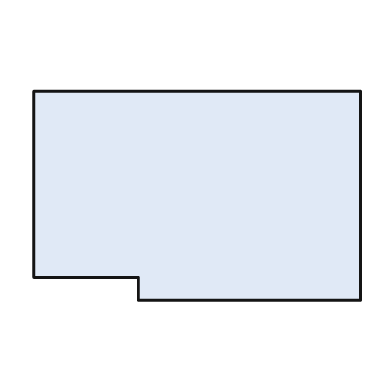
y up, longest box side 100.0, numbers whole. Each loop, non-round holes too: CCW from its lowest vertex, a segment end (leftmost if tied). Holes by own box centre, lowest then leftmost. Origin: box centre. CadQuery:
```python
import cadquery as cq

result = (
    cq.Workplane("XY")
    .moveTo(-18.0, -32.0)
    .lineTo(50.0, -32.0)
    .lineTo(50.0, 32.0)
    .lineTo(-50.0, 32.0)
    .lineTo(-50.0, -25.0)
    .lineTo(-18.0, -25.0)
    .close()
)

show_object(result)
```